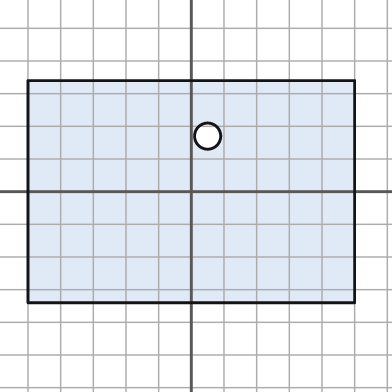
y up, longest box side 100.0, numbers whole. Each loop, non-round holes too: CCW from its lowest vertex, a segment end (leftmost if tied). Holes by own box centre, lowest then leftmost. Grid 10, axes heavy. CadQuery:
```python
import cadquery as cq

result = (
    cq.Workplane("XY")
    .moveTo(-50.0, -34.0)
    .lineTo(50.0, -34.0)
    .lineTo(50.0, 34.0)
    .lineTo(-50.0, 34.0)
    .close()
    .moveTo(5.0, 17.0)
    .circle(4.0)
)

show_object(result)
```